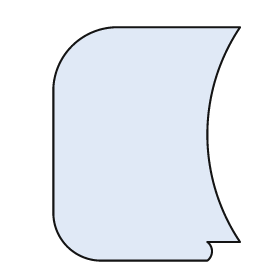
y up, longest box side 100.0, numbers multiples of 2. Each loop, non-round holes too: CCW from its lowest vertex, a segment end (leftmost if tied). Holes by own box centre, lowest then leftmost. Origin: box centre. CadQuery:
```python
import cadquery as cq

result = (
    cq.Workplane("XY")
    .moveTo(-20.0, -50.0)
    .lineTo(26.0, -50.0)
    .threePointArc((28.0, -46.0), (26.0, -42.0))
    .lineTo(40.0, -42.0)
    .threePointArc((26.0, 4.0), (40.0, 50.0))
    .lineTo(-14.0, 50.0)
    .threePointArc((-32.0, 42.0), (-40.0, 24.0))
    .lineTo(-40.0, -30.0)
    .threePointArc((-34.0, -44.0), (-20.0, -50.0))
    .close()
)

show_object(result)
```